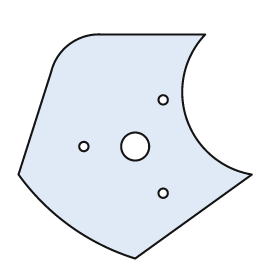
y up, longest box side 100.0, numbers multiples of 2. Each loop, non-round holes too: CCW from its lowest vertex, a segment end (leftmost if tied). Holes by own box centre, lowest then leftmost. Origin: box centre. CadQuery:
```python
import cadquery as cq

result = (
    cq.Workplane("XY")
    .moveTo(0.0, -48.0)
    .lineTo(50.0, -12.0)
    .threePointArc((22.0, 12.0), (30.0, 48.0))
    .lineTo(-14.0, 48.0)
    .threePointArc((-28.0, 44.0), (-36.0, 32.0))
    .lineTo(-50.0, -12.0)
    .threePointArc((-28.0, -34.0), (0.0, -48.0))
    .close()
    .moveTo(12.0, -20.0)
    .circle(2.0)
    .moveTo(-22.0, 0.0)
    .circle(2.0)
    .moveTo(0.0, 0.0)
    .circle(6.0)
    .moveTo(12.0, 20.0)
    .circle(2.0)
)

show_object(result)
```